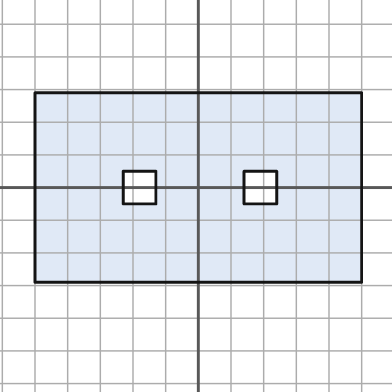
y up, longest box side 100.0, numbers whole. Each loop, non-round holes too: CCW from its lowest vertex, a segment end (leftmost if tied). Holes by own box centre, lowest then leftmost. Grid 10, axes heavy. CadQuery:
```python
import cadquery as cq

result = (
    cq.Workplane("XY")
    .moveTo(-50.0, -29.0)
    .lineTo(50.0, -29.0)
    .lineTo(50.0, 29.0)
    .lineTo(-50.0, 29.0)
    .close()
    .moveTo(-23.0, -5.0)
    .lineTo(-13.0, -5.0)
    .lineTo(-13.0, 5.0)
    .lineTo(-23.0, 5.0)
    .close()
    .moveTo(14.0, -5.0)
    .lineTo(24.0, -5.0)
    .lineTo(24.0, 5.0)
    .lineTo(14.0, 5.0)
    .close()
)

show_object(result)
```